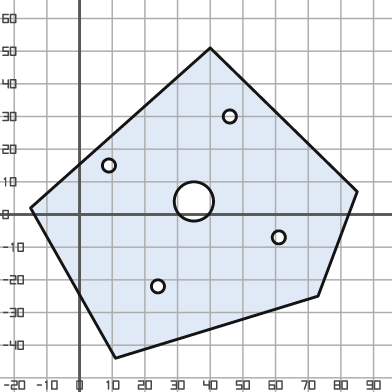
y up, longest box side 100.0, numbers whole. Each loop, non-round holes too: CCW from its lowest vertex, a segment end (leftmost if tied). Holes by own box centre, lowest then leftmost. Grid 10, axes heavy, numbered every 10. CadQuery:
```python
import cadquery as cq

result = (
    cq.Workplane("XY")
    .moveTo(11.0, -44.0)
    .lineTo(73.0, -25.0)
    .lineTo(85.0, 7.0)
    .lineTo(40.0, 51.0)
    .lineTo(-15.0, 2.0)
    .close()
    .moveTo(24.0, -22.0)
    .circle(2.0)
    .moveTo(61.0, -7.0)
    .circle(2.0)
    .moveTo(35.0, 4.0)
    .circle(6.0)
    .moveTo(9.0, 15.0)
    .circle(2.0)
    .moveTo(46.0, 30.0)
    .circle(2.0)
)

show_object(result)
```